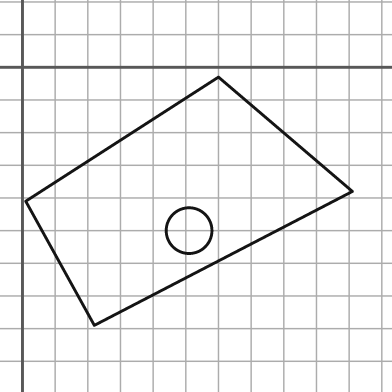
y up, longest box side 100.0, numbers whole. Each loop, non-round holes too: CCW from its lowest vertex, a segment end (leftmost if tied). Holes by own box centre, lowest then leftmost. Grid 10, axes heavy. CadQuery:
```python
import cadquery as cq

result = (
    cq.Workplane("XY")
    .moveTo(22.0, -79.0)
    .lineTo(101.0, -38.0)
    .lineTo(60.0, -3.0)
    .lineTo(1.0, -41.0)
    .close()
    .moveTo(51.0, -50.0)
    .circle(7.0)
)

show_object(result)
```